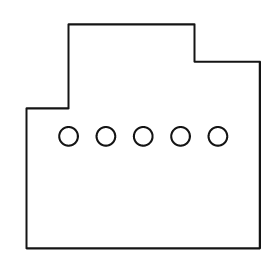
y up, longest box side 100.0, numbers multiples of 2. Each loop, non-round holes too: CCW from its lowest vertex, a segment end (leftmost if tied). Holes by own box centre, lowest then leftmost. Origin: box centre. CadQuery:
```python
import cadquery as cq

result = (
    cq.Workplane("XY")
    .moveTo(-50.0, -48.0)
    .lineTo(50.0, -48.0)
    .lineTo(50.0, 32.0)
    .lineTo(22.0, 32.0)
    .lineTo(22.0, 48.0)
    .lineTo(-32.0, 48.0)
    .lineTo(-32.0, 12.0)
    .lineTo(-50.0, 12.0)
    .close()
    .moveTo(-32.0, 0.0)
    .circle(4.0)
    .moveTo(-16.0, 0.0)
    .circle(4.0)
    .moveTo(0.0, 0.0)
    .circle(4.0)
    .moveTo(16.0, 0.0)
    .circle(4.0)
    .moveTo(32.0, 0.0)
    .circle(4.0)
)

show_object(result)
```